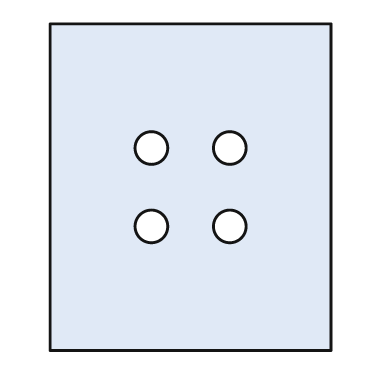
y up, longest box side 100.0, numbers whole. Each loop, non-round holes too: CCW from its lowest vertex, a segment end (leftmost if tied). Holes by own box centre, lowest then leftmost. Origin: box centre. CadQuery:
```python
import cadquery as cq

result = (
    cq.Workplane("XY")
    .moveTo(-43.0, -50.0)
    .lineTo(43.0, -50.0)
    .lineTo(43.0, 50.0)
    .lineTo(-43.0, 50.0)
    .close()
    .moveTo(-12.0, -12.0)
    .circle(5.0)
    .moveTo(12.0, -12.0)
    .circle(5.0)
    .moveTo(-12.0, 12.0)
    .circle(5.0)
    .moveTo(12.0, 12.0)
    .circle(5.0)
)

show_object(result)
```